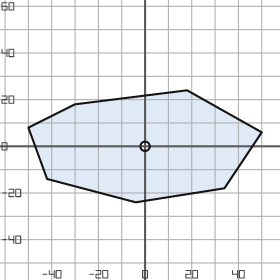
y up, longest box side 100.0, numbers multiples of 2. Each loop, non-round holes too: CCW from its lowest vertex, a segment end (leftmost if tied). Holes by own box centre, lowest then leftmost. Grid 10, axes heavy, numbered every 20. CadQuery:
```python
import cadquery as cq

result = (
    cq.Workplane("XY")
    .moveTo(-4.0, -24.0)
    .lineTo(34.0, -18.0)
    .lineTo(50.0, 6.0)
    .lineTo(18.0, 24.0)
    .lineTo(-30.0, 18.0)
    .lineTo(-50.0, 8.0)
    .lineTo(-42.0, -14.0)
    .close()
    .moveTo(0.0, 0.0)
    .circle(2.0)
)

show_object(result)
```